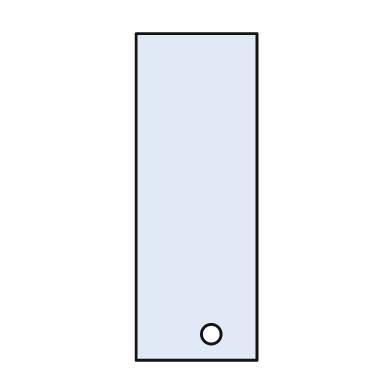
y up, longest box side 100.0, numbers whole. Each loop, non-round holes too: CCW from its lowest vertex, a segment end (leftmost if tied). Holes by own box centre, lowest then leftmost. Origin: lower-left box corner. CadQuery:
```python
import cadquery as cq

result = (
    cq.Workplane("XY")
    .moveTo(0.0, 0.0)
    .lineTo(37.0, 0.0)
    .lineTo(37.0, 100.0)
    .lineTo(0.0, 100.0)
    .close()
    .moveTo(23.0, 8.0)
    .circle(3.0)
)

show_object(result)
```